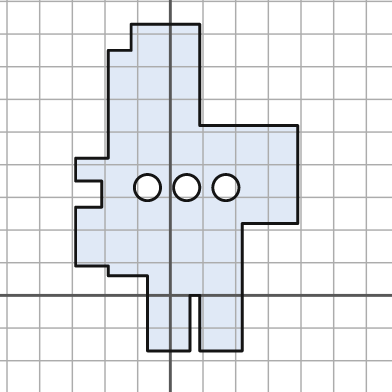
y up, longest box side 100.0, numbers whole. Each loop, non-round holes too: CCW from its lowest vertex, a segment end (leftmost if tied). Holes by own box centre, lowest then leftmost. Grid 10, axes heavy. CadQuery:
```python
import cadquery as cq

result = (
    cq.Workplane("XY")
    .moveTo(-7.0, -17.0)
    .lineTo(6.0, -17.0)
    .lineTo(6.0, 0.0)
    .lineTo(9.0, 0.0)
    .lineTo(9.0, -17.0)
    .lineTo(22.0, -17.0)
    .lineTo(22.0, 22.0)
    .lineTo(39.0, 22.0)
    .lineTo(39.0, 52.0)
    .lineTo(9.0, 52.0)
    .lineTo(9.0, 83.0)
    .lineTo(-12.0, 83.0)
    .lineTo(-12.0, 75.0)
    .lineTo(-19.0, 75.0)
    .lineTo(-19.0, 42.0)
    .lineTo(-29.0, 42.0)
    .lineTo(-29.0, 35.0)
    .lineTo(-21.0, 35.0)
    .lineTo(-21.0, 27.0)
    .lineTo(-29.0, 27.0)
    .lineTo(-29.0, 9.0)
    .lineTo(-19.0, 9.0)
    .lineTo(-19.0, 6.0)
    .lineTo(-7.0, 6.0)
    .close()
    .moveTo(-7.0, 33.0)
    .circle(4.0)
    .moveTo(5.0, 33.0)
    .circle(4.0)
    .moveTo(17.0, 33.0)
    .circle(4.0)
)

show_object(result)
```